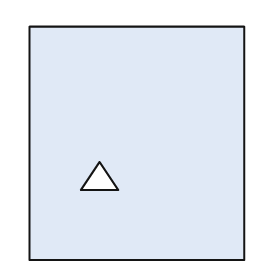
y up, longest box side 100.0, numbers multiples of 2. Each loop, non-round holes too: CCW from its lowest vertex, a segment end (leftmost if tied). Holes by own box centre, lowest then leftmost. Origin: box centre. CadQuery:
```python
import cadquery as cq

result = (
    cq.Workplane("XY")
    .moveTo(-46.0, -50.0)
    .lineTo(46.0, -50.0)
    .lineTo(46.0, 50.0)
    .lineTo(-46.0, 50.0)
    .close()
    .moveTo(-24.0, -20.0)
    .lineTo(-8.0, -20.0)
    .lineTo(-16.0, -8.0)
    .close()
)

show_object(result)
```